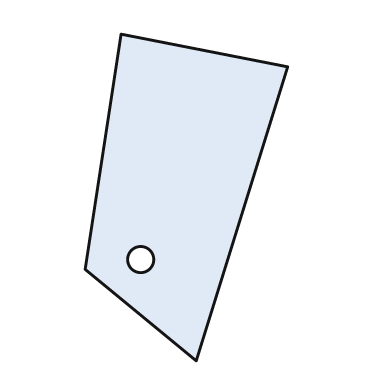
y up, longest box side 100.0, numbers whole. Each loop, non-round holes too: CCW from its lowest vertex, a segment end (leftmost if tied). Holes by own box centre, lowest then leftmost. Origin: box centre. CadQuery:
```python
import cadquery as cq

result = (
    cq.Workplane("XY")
    .moveTo(3.0, -50.0)
    .lineTo(31.0, 40.0)
    .lineTo(-20.0, 50.0)
    .lineTo(-31.0, -22.0)
    .close()
    .moveTo(-14.0, -19.0)
    .circle(4.0)
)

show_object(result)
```